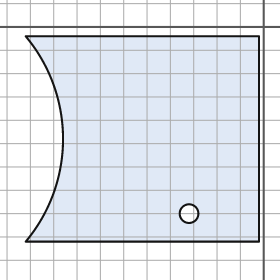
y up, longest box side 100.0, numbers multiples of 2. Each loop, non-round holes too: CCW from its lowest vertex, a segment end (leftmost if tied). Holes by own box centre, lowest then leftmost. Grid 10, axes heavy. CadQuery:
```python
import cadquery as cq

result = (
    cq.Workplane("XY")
    .moveTo(-102.0, -92.0)
    .lineTo(-2.0, -92.0)
    .lineTo(-2.0, -4.0)
    .lineTo(-102.0, -4.0)
    .threePointArc((-86.0, -48.0), (-102.0, -92.0))
    .close()
    .moveTo(-32.0, -80.0)
    .circle(4.0)
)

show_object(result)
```